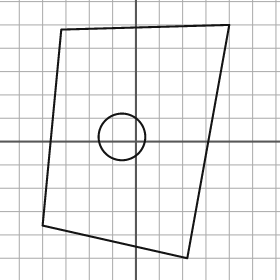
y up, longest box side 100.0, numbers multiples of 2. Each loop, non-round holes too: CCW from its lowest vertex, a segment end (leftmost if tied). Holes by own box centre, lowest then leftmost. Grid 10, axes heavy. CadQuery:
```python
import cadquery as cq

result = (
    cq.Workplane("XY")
    .moveTo(22.0, -50.0)
    .lineTo(40.0, 50.0)
    .lineTo(-32.0, 48.0)
    .lineTo(-40.0, -36.0)
    .close()
    .moveTo(-6.0, 2.0)
    .circle(10.0)
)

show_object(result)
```